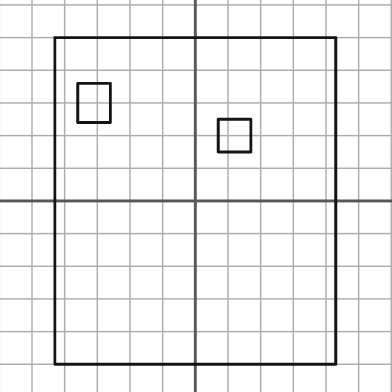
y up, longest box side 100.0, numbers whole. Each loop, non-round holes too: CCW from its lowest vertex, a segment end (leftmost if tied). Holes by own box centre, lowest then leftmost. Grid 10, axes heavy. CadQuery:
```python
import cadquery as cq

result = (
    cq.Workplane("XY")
    .moveTo(-43.0, -50.0)
    .lineTo(43.0, -50.0)
    .lineTo(43.0, 50.0)
    .lineTo(-43.0, 50.0)
    .close()
    .moveTo(7.0, 15.0)
    .lineTo(17.0, 15.0)
    .lineTo(17.0, 25.0)
    .lineTo(7.0, 25.0)
    .close()
    .moveTo(-36.0, 24.0)
    .lineTo(-26.0, 24.0)
    .lineTo(-26.0, 36.0)
    .lineTo(-36.0, 36.0)
    .close()
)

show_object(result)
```